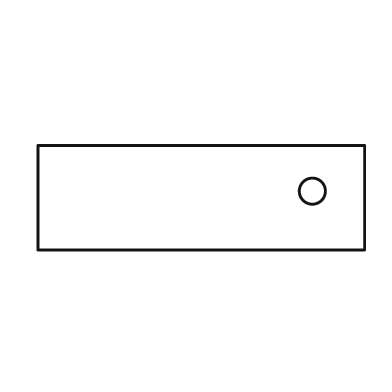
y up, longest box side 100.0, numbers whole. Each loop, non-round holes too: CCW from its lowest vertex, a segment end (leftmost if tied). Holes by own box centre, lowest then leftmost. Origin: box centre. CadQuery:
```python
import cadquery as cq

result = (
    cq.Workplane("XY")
    .moveTo(-50.0, -16.0)
    .lineTo(50.0, -16.0)
    .lineTo(50.0, 16.0)
    .lineTo(-50.0, 16.0)
    .close()
    .moveTo(34.0, 2.0)
    .circle(4.0)
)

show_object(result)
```